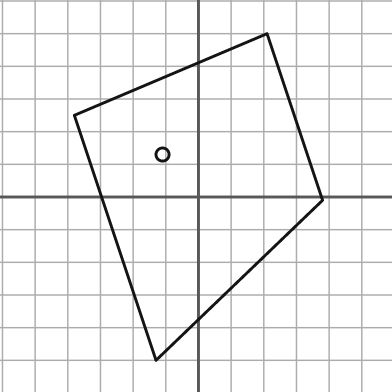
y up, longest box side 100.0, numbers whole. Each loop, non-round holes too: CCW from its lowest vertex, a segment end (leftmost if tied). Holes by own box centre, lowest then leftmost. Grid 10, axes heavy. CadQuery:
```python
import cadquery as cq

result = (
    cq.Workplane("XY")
    .moveTo(-13.0, -50.0)
    .lineTo(38.0, -1.0)
    .lineTo(21.0, 50.0)
    .lineTo(-38.0, 25.0)
    .close()
    .moveTo(-11.0, 13.0)
    .circle(2.0)
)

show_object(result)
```